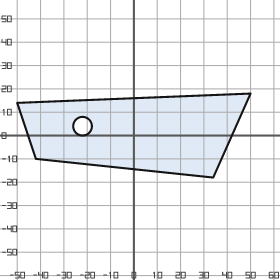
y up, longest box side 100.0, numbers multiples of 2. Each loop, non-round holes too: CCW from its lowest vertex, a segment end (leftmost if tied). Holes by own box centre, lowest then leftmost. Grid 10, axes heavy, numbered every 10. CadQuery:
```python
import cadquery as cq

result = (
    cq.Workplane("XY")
    .moveTo(34.0, -18.0)
    .lineTo(50.0, 18.0)
    .lineTo(-50.0, 14.0)
    .lineTo(-42.0, -10.0)
    .close()
    .moveTo(-22.0, 4.0)
    .circle(4.0)
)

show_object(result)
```